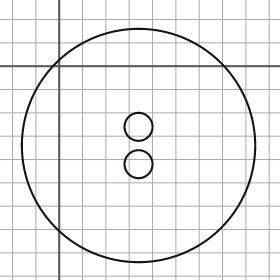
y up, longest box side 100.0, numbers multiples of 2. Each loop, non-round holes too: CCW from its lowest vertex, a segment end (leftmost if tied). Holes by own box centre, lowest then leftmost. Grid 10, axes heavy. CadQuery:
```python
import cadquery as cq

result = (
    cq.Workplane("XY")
    .moveTo(34.0, -34.0)
    .circle(50.0)
    .moveTo(34.0, -42.0)
    .circle(6.0)
    .moveTo(34.0, -26.0)
    .circle(6.0)
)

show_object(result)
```